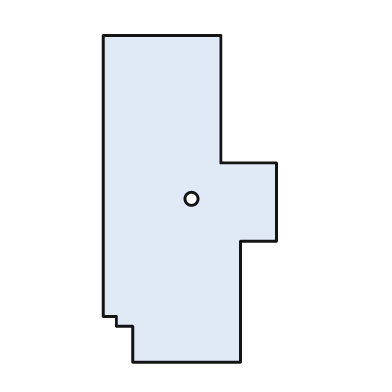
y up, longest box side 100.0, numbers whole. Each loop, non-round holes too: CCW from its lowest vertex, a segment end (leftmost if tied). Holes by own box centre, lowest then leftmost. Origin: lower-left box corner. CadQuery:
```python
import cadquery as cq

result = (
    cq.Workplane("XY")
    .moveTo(9.0, 0.0)
    .lineTo(42.0, 0.0)
    .lineTo(42.0, 37.0)
    .lineTo(53.0, 37.0)
    .lineTo(53.0, 61.0)
    .lineTo(36.0, 61.0)
    .lineTo(36.0, 100.0)
    .lineTo(0.0, 100.0)
    .lineTo(0.0, 14.0)
    .lineTo(4.0, 14.0)
    .lineTo(4.0, 11.0)
    .lineTo(9.0, 11.0)
    .close()
    .moveTo(27.0, 50.0)
    .circle(2.0)
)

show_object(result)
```